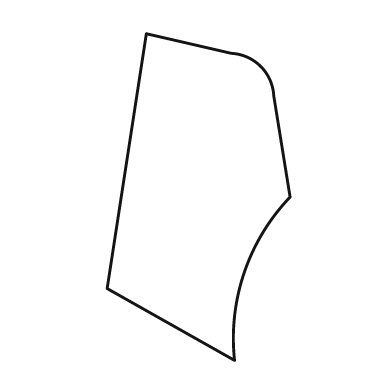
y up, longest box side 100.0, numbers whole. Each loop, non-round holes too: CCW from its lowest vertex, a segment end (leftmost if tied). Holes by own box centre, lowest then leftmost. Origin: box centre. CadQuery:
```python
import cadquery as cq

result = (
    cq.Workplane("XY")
    .moveTo(11.0, -50.0)
    .threePointArc((14.0, -23.0), (28.0, 0.0))
    .lineTo(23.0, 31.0)
    .threePointArc((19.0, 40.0), (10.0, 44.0))
    .lineTo(-16.0, 50.0)
    .lineTo(-28.0, -28.0)
    .close()
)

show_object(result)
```